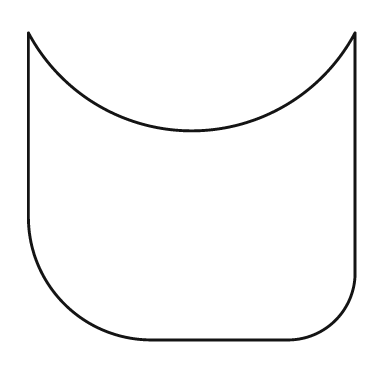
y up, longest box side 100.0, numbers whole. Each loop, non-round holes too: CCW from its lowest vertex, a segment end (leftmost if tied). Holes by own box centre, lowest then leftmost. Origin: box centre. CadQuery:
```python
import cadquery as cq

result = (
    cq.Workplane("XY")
    .moveTo(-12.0, -47.0)
    .lineTo(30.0, -47.0)
    .threePointArc((44.0, -41.0), (50.0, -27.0))
    .lineTo(50.0, 47.0)
    .threePointArc((0.0, 17.0), (-50.0, 47.0))
    .lineTo(-50.0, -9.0)
    .threePointArc((-39.0, -36.0), (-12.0, -47.0))
    .close()
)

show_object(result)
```